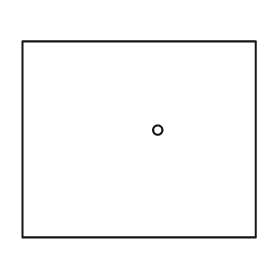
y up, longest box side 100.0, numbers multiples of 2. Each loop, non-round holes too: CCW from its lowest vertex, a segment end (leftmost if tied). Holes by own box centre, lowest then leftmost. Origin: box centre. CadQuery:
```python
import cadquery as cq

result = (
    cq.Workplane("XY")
    .moveTo(-50.0, -42.0)
    .lineTo(50.0, -42.0)
    .lineTo(50.0, 42.0)
    .lineTo(-50.0, 42.0)
    .close()
    .moveTo(8.0, 4.0)
    .circle(2.0)
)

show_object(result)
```